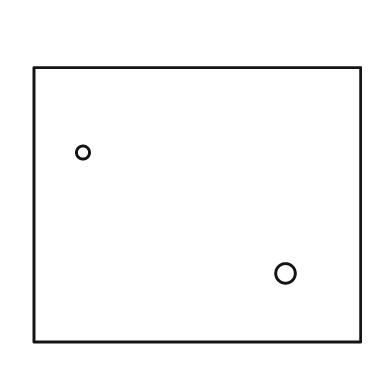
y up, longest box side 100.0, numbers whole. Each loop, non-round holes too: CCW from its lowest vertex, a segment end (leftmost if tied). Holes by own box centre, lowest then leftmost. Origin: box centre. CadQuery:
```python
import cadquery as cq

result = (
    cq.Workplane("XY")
    .moveTo(-50.0, -42.0)
    .lineTo(50.0, -42.0)
    .lineTo(50.0, 42.0)
    .lineTo(-50.0, 42.0)
    .close()
    .moveTo(27.0, -21.0)
    .circle(3.0)
    .moveTo(-35.0, 16.0)
    .circle(2.0)
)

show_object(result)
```